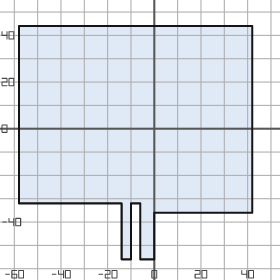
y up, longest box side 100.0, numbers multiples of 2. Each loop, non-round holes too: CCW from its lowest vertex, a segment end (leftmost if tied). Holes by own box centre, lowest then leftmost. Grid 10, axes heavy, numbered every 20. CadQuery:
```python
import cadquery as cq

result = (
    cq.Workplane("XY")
    .moveTo(-14.0, -56.0)
    .lineTo(-10.0, -56.0)
    .lineTo(-10.0, -32.0)
    .lineTo(-6.0, -32.0)
    .lineTo(-6.0, -56.0)
    .lineTo(0.0, -56.0)
    .lineTo(0.0, -36.0)
    .lineTo(42.0, -36.0)
    .lineTo(42.0, 44.0)
    .lineTo(-58.0, 44.0)
    .lineTo(-58.0, -32.0)
    .lineTo(-14.0, -32.0)
    .close()
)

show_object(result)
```